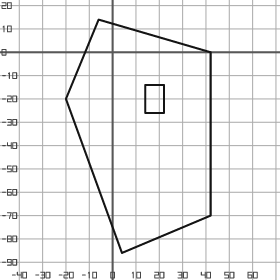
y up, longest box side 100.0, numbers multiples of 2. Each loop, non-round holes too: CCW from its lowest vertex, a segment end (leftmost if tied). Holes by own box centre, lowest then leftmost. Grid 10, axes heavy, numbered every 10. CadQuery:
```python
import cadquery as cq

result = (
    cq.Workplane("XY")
    .moveTo(4.0, -86.0)
    .lineTo(42.0, -70.0)
    .lineTo(42.0, 0.0)
    .lineTo(-6.0, 14.0)
    .lineTo(-20.0, -20.0)
    .close()
    .moveTo(14.0, -26.0)
    .lineTo(22.0, -26.0)
    .lineTo(22.0, -14.0)
    .lineTo(14.0, -14.0)
    .close()
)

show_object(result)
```